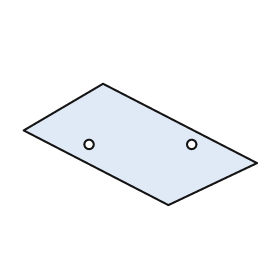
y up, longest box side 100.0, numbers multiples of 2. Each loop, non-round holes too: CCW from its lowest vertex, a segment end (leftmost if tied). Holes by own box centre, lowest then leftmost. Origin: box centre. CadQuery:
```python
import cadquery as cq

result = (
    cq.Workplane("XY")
    .moveTo(12.0, -26.0)
    .lineTo(50.0, -8.0)
    .lineTo(-16.0, 26.0)
    .lineTo(-50.0, 6.0)
    .close()
    .moveTo(-22.0, 0.0)
    .circle(2.0)
    .moveTo(22.0, 0.0)
    .circle(2.0)
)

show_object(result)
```